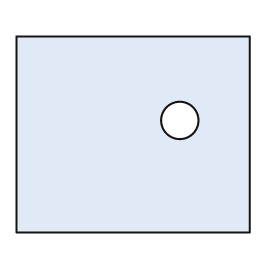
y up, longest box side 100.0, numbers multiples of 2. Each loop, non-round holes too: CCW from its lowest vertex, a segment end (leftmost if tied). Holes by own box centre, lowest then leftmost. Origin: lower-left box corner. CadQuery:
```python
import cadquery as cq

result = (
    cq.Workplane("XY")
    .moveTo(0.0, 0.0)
    .lineTo(100.0, 0.0)
    .lineTo(100.0, 84.0)
    .lineTo(0.0, 84.0)
    .close()
    .moveTo(70.0, 48.0)
    .circle(8.0)
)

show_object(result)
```